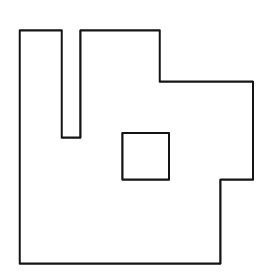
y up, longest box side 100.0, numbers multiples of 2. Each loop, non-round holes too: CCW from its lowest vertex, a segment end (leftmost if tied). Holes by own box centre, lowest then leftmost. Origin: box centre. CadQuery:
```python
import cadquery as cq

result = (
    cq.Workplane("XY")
    .moveTo(-50.0, -50.0)
    .lineTo(36.0, -50.0)
    .lineTo(36.0, -14.0)
    .lineTo(50.0, -14.0)
    .lineTo(50.0, 28.0)
    .lineTo(10.0, 28.0)
    .lineTo(10.0, 50.0)
    .lineTo(-24.0, 50.0)
    .lineTo(-24.0, 4.0)
    .lineTo(-32.0, 4.0)
    .lineTo(-32.0, 50.0)
    .lineTo(-50.0, 50.0)
    .close()
    .moveTo(-6.0, -14.0)
    .lineTo(14.0, -14.0)
    .lineTo(14.0, 6.0)
    .lineTo(-6.0, 6.0)
    .close()
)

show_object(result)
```